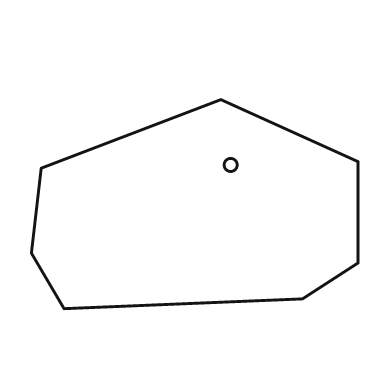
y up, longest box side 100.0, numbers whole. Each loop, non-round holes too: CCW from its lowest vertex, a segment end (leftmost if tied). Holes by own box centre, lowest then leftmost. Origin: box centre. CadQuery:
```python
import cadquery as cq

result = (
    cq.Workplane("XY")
    .moveTo(-40.0, -32.0)
    .lineTo(33.0, -29.0)
    .lineTo(50.0, -18.0)
    .lineTo(50.0, 13.0)
    .lineTo(8.0, 32.0)
    .lineTo(-47.0, 11.0)
    .lineTo(-50.0, -15.0)
    .close()
    .moveTo(11.0, 12.0)
    .circle(2.0)
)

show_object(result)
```